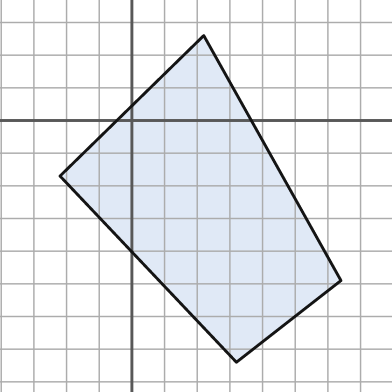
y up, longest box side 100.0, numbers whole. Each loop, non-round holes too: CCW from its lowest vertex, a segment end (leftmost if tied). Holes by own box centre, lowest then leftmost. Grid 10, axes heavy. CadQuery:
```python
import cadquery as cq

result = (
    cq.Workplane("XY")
    .moveTo(32.0, -74.0)
    .lineTo(64.0, -49.0)
    .lineTo(22.0, 26.0)
    .lineTo(-22.0, -17.0)
    .close()
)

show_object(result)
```